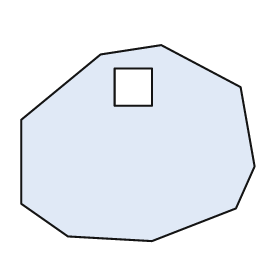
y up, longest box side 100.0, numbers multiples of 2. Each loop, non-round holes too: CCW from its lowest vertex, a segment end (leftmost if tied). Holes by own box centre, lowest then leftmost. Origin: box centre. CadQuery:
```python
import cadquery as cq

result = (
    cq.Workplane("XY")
    .moveTo(6.0, -42.0)
    .lineTo(42.0, -28.0)
    .lineTo(50.0, -10.0)
    .lineTo(44.0, 24.0)
    .lineTo(10.0, 42.0)
    .lineTo(-16.0, 38.0)
    .lineTo(-50.0, 10.0)
    .lineTo(-50.0, -26.0)
    .lineTo(-30.0, -40.0)
    .close()
    .moveTo(-10.0, 16.0)
    .lineTo(6.0, 16.0)
    .lineTo(6.0, 32.0)
    .lineTo(-10.0, 32.0)
    .close()
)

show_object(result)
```